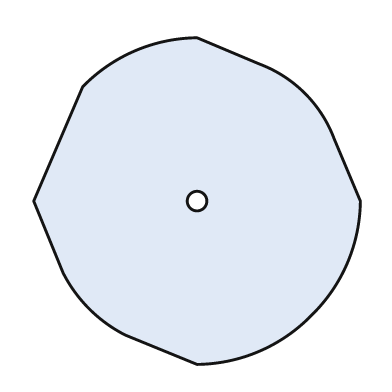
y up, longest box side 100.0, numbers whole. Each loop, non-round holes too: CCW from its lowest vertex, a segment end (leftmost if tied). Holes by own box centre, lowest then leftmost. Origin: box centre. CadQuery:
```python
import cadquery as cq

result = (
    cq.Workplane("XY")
    .moveTo(0.0, -50.0)
    .threePointArc((19.0, -46.0), (35.0, -35.0))
    .threePointArc((46.0, -19.0), (50.0, 0.0))
    .lineTo(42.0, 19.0)
    .threePointArc((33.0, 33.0), (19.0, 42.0))
    .lineTo(0.0, 50.0)
    .threePointArc((-19.0, 46.0), (-35.0, 35.0))
    .lineTo(-50.0, 0.0)
    .lineTo(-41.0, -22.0)
    .threePointArc((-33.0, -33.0), (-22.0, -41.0))
    .close()
    .moveTo(0.0, 0.0)
    .circle(3.0)
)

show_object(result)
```